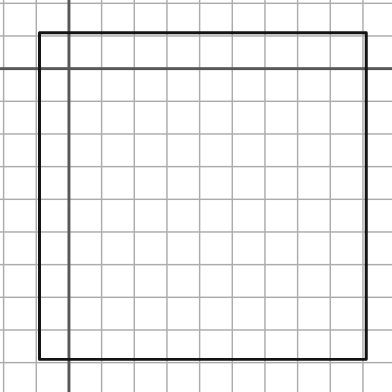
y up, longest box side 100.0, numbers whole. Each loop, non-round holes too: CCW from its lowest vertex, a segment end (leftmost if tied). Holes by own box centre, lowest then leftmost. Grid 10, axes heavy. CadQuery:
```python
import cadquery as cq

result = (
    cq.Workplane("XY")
    .moveTo(-9.0, -89.0)
    .lineTo(91.0, -89.0)
    .lineTo(91.0, 11.0)
    .lineTo(-9.0, 11.0)
    .close()
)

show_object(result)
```